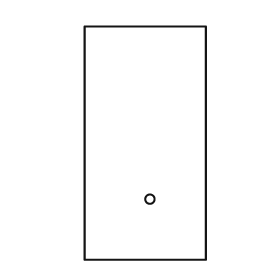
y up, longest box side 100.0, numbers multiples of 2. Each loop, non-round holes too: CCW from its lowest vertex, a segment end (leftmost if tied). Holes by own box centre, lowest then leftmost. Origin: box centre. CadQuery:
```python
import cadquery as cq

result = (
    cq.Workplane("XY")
    .moveTo(-26.0, -50.0)
    .lineTo(26.0, -50.0)
    .lineTo(26.0, 50.0)
    .lineTo(-26.0, 50.0)
    .close()
    .moveTo(2.0, -24.0)
    .circle(2.0)
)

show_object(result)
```